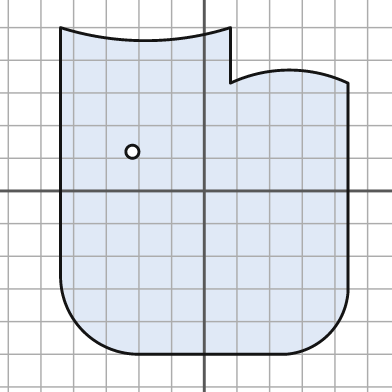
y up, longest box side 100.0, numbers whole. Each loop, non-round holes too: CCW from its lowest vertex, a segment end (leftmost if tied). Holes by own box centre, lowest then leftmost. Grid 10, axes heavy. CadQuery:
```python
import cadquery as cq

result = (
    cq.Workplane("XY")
    .moveTo(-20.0, -50.0)
    .lineTo(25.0, -50.0)
    .threePointArc((38.0, -44.0), (44.0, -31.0))
    .lineTo(44.0, 33.0)
    .threePointArc((26.0, 37.0), (8.0, 33.0))
    .lineTo(8.0, 50.0)
    .threePointArc((-18.0, 46.0), (-44.0, 50.0))
    .lineTo(-44.0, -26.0)
    .threePointArc((-37.0, -43.0), (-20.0, -50.0))
    .close()
    .moveTo(-22.0, 12.0)
    .circle(2.0)
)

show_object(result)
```